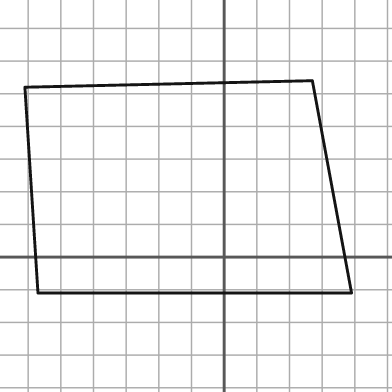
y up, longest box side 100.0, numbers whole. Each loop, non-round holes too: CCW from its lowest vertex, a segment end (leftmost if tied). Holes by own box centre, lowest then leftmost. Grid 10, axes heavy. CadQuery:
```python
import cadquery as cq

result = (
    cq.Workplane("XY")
    .moveTo(-57.0, -11.0)
    .lineTo(39.0, -11.0)
    .lineTo(27.0, 54.0)
    .lineTo(-61.0, 52.0)
    .close()
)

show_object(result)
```